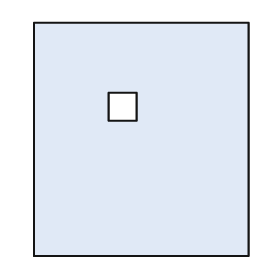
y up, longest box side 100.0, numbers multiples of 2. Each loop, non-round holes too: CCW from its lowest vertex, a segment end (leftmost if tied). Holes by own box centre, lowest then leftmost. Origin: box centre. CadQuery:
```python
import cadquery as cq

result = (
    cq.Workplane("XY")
    .moveTo(-46.0, -50.0)
    .lineTo(46.0, -50.0)
    .lineTo(46.0, 50.0)
    .lineTo(-46.0, 50.0)
    .close()
    .moveTo(-14.0, 8.0)
    .lineTo(-2.0, 8.0)
    .lineTo(-2.0, 20.0)
    .lineTo(-14.0, 20.0)
    .close()
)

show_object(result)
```